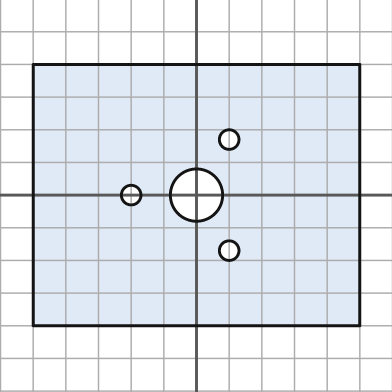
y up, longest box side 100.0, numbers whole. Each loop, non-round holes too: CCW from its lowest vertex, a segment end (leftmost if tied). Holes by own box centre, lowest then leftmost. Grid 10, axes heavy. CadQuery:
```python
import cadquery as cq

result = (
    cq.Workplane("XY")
    .moveTo(-50.0, -40.0)
    .lineTo(50.0, -40.0)
    .lineTo(50.0, 40.0)
    .lineTo(-50.0, 40.0)
    .close()
    .moveTo(10.0, -17.0)
    .circle(3.0)
    .moveTo(-20.0, 0.0)
    .circle(3.0)
    .moveTo(0.0, 0.0)
    .circle(8.0)
    .moveTo(10.0, 17.0)
    .circle(3.0)
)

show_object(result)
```